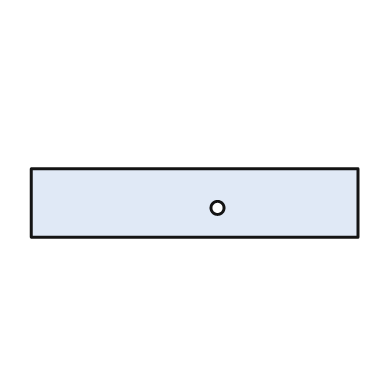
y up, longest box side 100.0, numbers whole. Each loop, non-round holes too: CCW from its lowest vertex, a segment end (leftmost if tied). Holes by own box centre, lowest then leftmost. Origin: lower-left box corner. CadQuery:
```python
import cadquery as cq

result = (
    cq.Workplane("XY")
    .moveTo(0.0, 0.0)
    .lineTo(100.0, 0.0)
    .lineTo(100.0, 21.0)
    .lineTo(0.0, 21.0)
    .close()
    .moveTo(57.0, 9.0)
    .circle(2.0)
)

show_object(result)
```